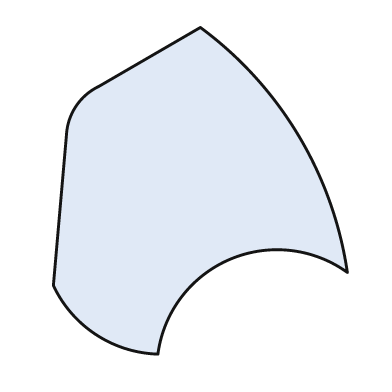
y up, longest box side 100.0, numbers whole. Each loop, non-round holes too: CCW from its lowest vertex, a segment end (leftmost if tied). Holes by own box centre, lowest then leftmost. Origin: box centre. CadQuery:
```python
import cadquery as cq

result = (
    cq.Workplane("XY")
    .moveTo(-13.0, -50.0)
    .threePointArc((9.0, -21.0), (45.0, -25.0))
    .threePointArc((30.0, 17.0), (0.0, 50.0))
    .lineTo(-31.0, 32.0)
    .threePointArc((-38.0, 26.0), (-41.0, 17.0))
    .lineTo(-45.0, -29.0)
    .threePointArc((-32.0, -44.0), (-13.0, -50.0))
    .close()
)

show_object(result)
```